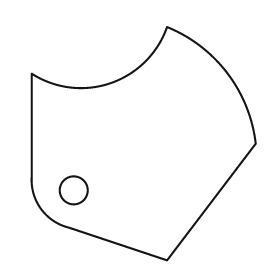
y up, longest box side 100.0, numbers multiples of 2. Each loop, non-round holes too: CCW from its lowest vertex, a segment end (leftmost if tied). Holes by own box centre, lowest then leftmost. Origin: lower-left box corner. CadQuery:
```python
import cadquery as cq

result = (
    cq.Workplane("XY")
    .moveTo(58.0, 0.0)
    .lineTo(96.0, 50.0)
    .threePointArc((84.0, 80.0), (58.0, 100.0))
    .threePointArc((34.0, 76.0), (0.0, 80.0))
    .lineTo(0.0, 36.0)
    .threePointArc((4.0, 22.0), (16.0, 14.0))
    .close()
    .moveTo(18.0, 30.0)
    .circle(6.0)
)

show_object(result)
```